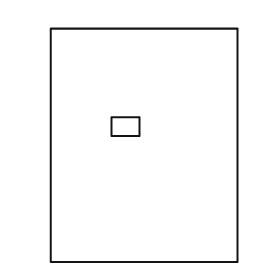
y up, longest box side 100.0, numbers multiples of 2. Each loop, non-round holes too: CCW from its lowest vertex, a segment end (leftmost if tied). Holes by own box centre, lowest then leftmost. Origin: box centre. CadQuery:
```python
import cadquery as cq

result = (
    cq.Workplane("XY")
    .moveTo(-40.0, -50.0)
    .lineTo(40.0, -50.0)
    .lineTo(40.0, 50.0)
    .lineTo(-40.0, 50.0)
    .close()
    .moveTo(-14.0, 4.0)
    .lineTo(-2.0, 4.0)
    .lineTo(-2.0, 12.0)
    .lineTo(-14.0, 12.0)
    .close()
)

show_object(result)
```